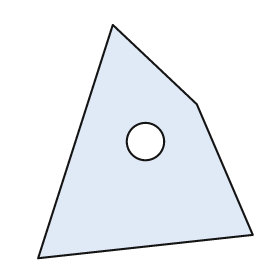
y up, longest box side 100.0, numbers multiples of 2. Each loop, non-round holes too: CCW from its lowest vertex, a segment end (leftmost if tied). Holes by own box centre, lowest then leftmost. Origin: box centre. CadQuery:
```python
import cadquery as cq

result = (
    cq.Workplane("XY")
    .moveTo(-46.0, -50.0)
    .lineTo(46.0, -40.0)
    .lineTo(22.0, 16.0)
    .lineTo(-14.0, 50.0)
    .close()
    .moveTo(0.0, 0.0)
    .circle(8.0)
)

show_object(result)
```